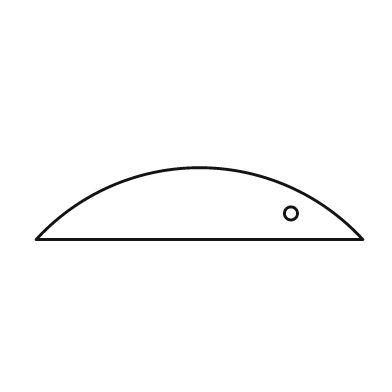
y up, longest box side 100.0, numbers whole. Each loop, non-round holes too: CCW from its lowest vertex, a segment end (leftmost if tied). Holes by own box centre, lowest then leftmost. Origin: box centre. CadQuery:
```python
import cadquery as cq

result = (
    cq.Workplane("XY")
    .moveTo(-50.0, -11.0)
    .lineTo(50.0, -11.0)
    .threePointArc((0.0, 11.0), (-50.0, -11.0))
    .close()
    .moveTo(28.0, -3.0)
    .circle(2.0)
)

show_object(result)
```